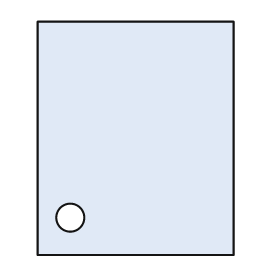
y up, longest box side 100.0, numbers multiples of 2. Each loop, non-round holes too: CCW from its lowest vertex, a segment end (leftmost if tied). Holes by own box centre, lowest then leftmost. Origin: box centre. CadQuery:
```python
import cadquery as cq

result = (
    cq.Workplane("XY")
    .moveTo(-42.0, -50.0)
    .lineTo(42.0, -50.0)
    .lineTo(42.0, 50.0)
    .lineTo(-42.0, 50.0)
    .close()
    .moveTo(-28.0, -34.0)
    .circle(6.0)
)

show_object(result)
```